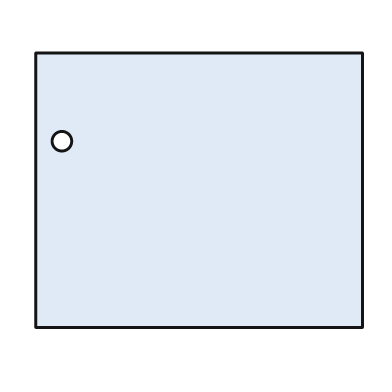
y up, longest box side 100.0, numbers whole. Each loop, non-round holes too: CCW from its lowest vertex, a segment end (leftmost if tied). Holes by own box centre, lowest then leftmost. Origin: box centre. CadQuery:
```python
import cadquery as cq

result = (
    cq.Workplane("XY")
    .moveTo(-50.0, -42.0)
    .lineTo(50.0, -42.0)
    .lineTo(50.0, 42.0)
    .lineTo(-50.0, 42.0)
    .close()
    .moveTo(-42.0, 15.0)
    .circle(3.0)
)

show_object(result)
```